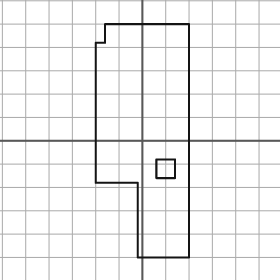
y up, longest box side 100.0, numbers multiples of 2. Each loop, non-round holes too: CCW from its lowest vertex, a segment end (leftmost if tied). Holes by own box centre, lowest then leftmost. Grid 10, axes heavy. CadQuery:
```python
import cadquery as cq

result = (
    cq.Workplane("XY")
    .moveTo(-2.0, -50.0)
    .lineTo(20.0, -50.0)
    .lineTo(20.0, 50.0)
    .lineTo(-16.0, 50.0)
    .lineTo(-16.0, 42.0)
    .lineTo(-20.0, 42.0)
    .lineTo(-20.0, -18.0)
    .lineTo(-2.0, -18.0)
    .close()
    .moveTo(6.0, -16.0)
    .lineTo(14.0, -16.0)
    .lineTo(14.0, -8.0)
    .lineTo(6.0, -8.0)
    .close()
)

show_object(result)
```